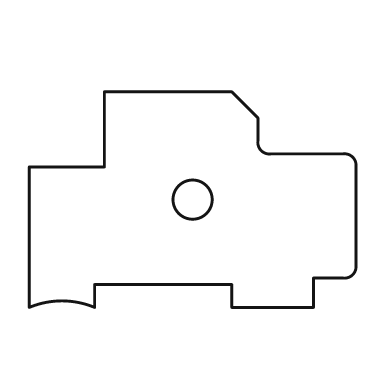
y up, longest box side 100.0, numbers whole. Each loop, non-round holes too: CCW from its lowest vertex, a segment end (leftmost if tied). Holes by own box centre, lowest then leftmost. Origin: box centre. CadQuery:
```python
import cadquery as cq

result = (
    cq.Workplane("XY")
    .moveTo(-50.0, -33.0)
    .threePointArc((-40.0, -31.0), (-30.0, -33.0))
    .lineTo(-30.0, -26.0)
    .lineTo(12.0, -26.0)
    .lineTo(12.0, -33.0)
    .lineTo(37.0, -33.0)
    .lineTo(37.0, -24.0)
    .lineTo(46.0, -24.0)
    .threePointArc((49.0, -23.0), (50.0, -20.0))
    .lineTo(50.0, 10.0)
    .threePointArc((49.0, 13.0), (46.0, 14.0))
    .lineTo(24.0, 14.0)
    .threePointArc((21.0, 15.0), (20.0, 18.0))
    .lineTo(20.0, 25.0)
    .lineTo(12.0, 33.0)
    .lineTo(-27.0, 33.0)
    .lineTo(-27.0, 10.0)
    .lineTo(-50.0, 10.0)
    .close()
    .moveTo(0.0, 0.0)
    .circle(6.0)
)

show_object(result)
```